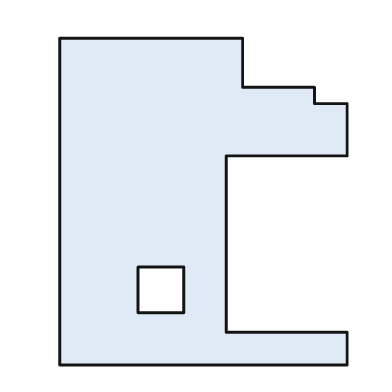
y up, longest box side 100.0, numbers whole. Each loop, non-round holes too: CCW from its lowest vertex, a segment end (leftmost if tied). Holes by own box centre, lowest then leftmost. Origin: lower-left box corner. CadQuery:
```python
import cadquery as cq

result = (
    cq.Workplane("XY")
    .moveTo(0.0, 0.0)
    .lineTo(88.0, 0.0)
    .lineTo(88.0, 10.0)
    .lineTo(51.0, 10.0)
    .lineTo(51.0, 64.0)
    .lineTo(88.0, 64.0)
    .lineTo(88.0, 80.0)
    .lineTo(78.0, 80.0)
    .lineTo(78.0, 85.0)
    .lineTo(56.0, 85.0)
    .lineTo(56.0, 100.0)
    .lineTo(0.0, 100.0)
    .close()
    .moveTo(24.0, 16.0)
    .lineTo(38.0, 16.0)
    .lineTo(38.0, 30.0)
    .lineTo(24.0, 30.0)
    .close()
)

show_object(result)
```